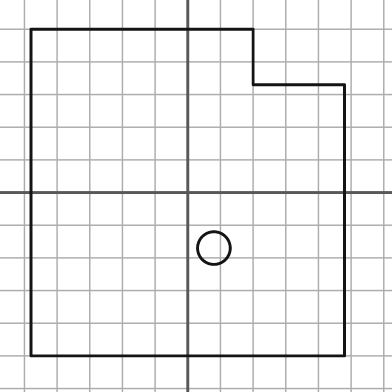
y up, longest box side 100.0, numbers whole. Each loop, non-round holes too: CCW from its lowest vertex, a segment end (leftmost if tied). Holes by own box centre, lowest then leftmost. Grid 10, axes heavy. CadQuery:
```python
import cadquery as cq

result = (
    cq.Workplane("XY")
    .moveTo(-48.0, -50.0)
    .lineTo(48.0, -50.0)
    .lineTo(48.0, 33.0)
    .lineTo(20.0, 33.0)
    .lineTo(20.0, 50.0)
    .lineTo(-48.0, 50.0)
    .close()
    .moveTo(8.0, -17.0)
    .circle(5.0)
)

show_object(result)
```